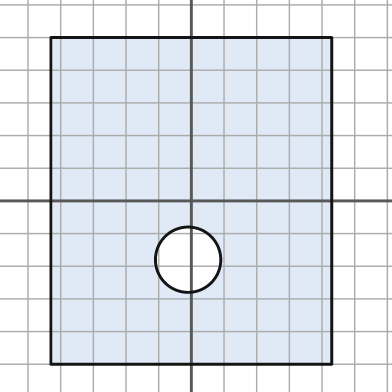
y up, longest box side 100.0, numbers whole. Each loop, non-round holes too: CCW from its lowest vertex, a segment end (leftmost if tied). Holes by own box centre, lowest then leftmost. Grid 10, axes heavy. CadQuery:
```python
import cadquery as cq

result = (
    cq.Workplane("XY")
    .moveTo(-43.0, -50.0)
    .lineTo(43.0, -50.0)
    .lineTo(43.0, 50.0)
    .lineTo(-43.0, 50.0)
    .close()
    .moveTo(-1.0, -18.0)
    .circle(10.0)
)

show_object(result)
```